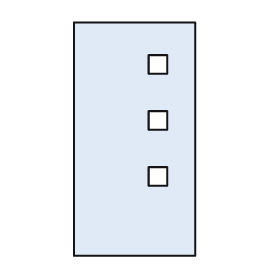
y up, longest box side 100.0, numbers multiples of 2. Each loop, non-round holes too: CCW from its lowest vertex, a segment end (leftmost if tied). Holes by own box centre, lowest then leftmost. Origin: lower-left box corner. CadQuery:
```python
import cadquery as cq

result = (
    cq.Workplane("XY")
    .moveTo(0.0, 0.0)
    .lineTo(52.0, 0.0)
    .lineTo(52.0, 100.0)
    .lineTo(0.0, 100.0)
    .close()
    .moveTo(32.0, 30.0)
    .lineTo(40.0, 30.0)
    .lineTo(40.0, 38.0)
    .lineTo(32.0, 38.0)
    .close()
    .moveTo(32.0, 54.0)
    .lineTo(40.0, 54.0)
    .lineTo(40.0, 62.0)
    .lineTo(32.0, 62.0)
    .close()
    .moveTo(32.0, 78.0)
    .lineTo(40.0, 78.0)
    .lineTo(40.0, 86.0)
    .lineTo(32.0, 86.0)
    .close()
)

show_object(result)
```